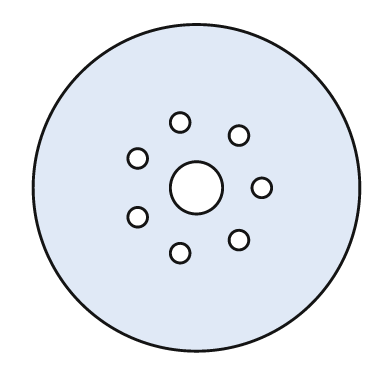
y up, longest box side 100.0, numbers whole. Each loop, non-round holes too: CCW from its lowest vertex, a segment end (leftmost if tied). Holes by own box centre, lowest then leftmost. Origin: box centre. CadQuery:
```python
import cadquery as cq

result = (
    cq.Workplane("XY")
    .moveTo(0.0, 0.0)
    .circle(50.0)
    .moveTo(-5.0, -20.0)
    .circle(3.0)
    .moveTo(13.0, -16.0)
    .circle(3.0)
    .moveTo(-18.0, -9.0)
    .circle(3.0)
    .moveTo(0.0, 0.0)
    .circle(8.0)
    .moveTo(20.0, 0.0)
    .circle(3.0)
    .moveTo(-18.0, 9.0)
    .circle(3.0)
    .moveTo(13.0, 16.0)
    .circle(3.0)
    .moveTo(-5.0, 20.0)
    .circle(3.0)
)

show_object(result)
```